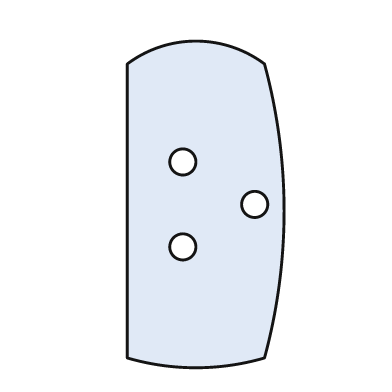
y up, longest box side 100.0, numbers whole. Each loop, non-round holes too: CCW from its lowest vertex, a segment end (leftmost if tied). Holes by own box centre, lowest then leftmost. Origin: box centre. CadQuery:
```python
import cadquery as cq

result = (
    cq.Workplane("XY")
    .moveTo(-24.0, -47.0)
    .threePointArc((-3.0, -50.0), (18.0, -47.0))
    .threePointArc((24.0, -2.0), (18.0, 43.0))
    .threePointArc((-3.0, 50.0), (-24.0, 43.0))
    .close()
    .moveTo(-7.0, -13.0)
    .circle(4.0)
    .moveTo(15.0, 0.0)
    .circle(4.0)
    .moveTo(-7.0, 13.0)
    .circle(4.0)
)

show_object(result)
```